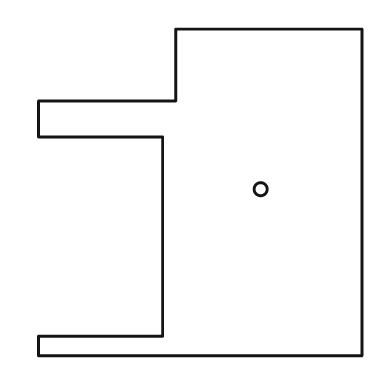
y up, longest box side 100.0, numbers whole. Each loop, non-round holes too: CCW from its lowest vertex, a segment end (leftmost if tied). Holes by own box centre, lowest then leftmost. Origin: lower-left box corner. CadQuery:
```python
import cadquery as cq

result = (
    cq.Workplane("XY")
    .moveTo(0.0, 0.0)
    .lineTo(99.0, 0.0)
    .lineTo(99.0, 100.0)
    .lineTo(42.0, 100.0)
    .lineTo(42.0, 78.0)
    .lineTo(0.0, 78.0)
    .lineTo(0.0, 67.0)
    .lineTo(38.0, 67.0)
    .lineTo(38.0, 6.0)
    .lineTo(0.0, 6.0)
    .close()
    .moveTo(68.0, 51.0)
    .circle(2.0)
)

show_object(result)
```